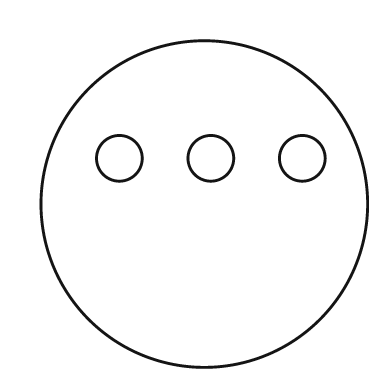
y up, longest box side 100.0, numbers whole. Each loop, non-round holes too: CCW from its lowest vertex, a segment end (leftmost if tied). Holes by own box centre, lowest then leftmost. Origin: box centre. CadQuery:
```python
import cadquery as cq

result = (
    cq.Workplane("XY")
    .moveTo(0.0, 0.0)
    .circle(50.0)
    .moveTo(-26.0, 14.0)
    .circle(7.0)
    .moveTo(2.0, 14.0)
    .circle(7.0)
    .moveTo(30.0, 14.0)
    .circle(7.0)
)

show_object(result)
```